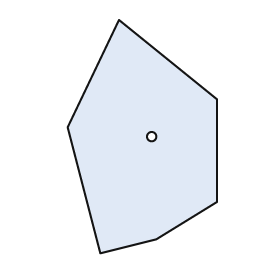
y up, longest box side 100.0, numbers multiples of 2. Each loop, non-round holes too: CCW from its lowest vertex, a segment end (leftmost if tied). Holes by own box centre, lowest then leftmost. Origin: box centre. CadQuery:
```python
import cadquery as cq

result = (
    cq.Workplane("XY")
    .moveTo(-18.0, -50.0)
    .lineTo(6.0, -44.0)
    .lineTo(32.0, -28.0)
    .lineTo(32.0, 16.0)
    .lineTo(-10.0, 50.0)
    .lineTo(-32.0, 4.0)
    .close()
    .moveTo(4.0, 0.0)
    .circle(2.0)
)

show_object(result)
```